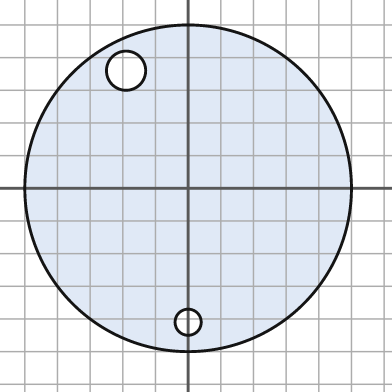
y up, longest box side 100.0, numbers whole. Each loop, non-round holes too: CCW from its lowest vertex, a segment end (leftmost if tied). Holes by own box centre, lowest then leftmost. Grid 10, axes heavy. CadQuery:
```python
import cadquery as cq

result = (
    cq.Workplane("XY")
    .moveTo(0.0, 0.0)
    .circle(50.0)
    .moveTo(0.0, -41.0)
    .circle(4.0)
    .moveTo(-19.0, 36.0)
    .circle(6.0)
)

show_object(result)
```